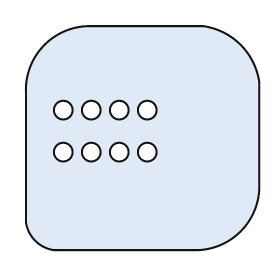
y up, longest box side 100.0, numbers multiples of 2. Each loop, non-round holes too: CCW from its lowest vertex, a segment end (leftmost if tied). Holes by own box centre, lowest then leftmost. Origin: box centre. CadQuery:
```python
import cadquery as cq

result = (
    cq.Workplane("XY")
    .moveTo(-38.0, -48.0)
    .lineTo(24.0, -48.0)
    .threePointArc((42.0, -40.0), (50.0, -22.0))
    .lineTo(50.0, 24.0)
    .threePointArc((42.0, 40.0), (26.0, 48.0))
    .lineTo(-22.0, 48.0)
    .threePointArc((-42.0, 40.0), (-50.0, 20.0))
    .lineTo(-50.0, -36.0)
    .threePointArc((-46.0, -44.0), (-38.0, -48.0))
    .close()
    .moveTo(-34.0, -6.0)
    .circle(4.0)
    .moveTo(-22.0, -6.0)
    .circle(4.0)
    .moveTo(-10.0, -6.0)
    .circle(4.0)
    .moveTo(2.0, -6.0)
    .circle(4.0)
    .moveTo(-34.0, 12.0)
    .circle(4.0)
    .moveTo(-22.0, 12.0)
    .circle(4.0)
    .moveTo(-10.0, 12.0)
    .circle(4.0)
    .moveTo(2.0, 12.0)
    .circle(4.0)
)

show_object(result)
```